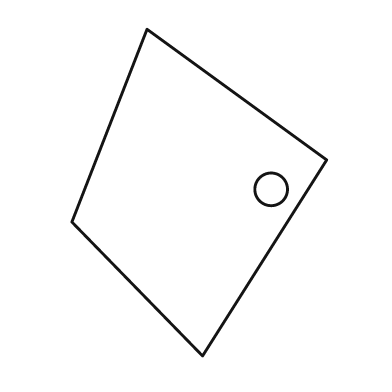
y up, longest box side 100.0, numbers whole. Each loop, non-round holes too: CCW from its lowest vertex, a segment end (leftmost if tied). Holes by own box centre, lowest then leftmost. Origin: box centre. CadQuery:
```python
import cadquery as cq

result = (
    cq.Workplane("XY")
    .moveTo(1.0, -50.0)
    .lineTo(39.0, 10.0)
    .lineTo(-16.0, 50.0)
    .lineTo(-39.0, -9.0)
    .close()
    .moveTo(22.0, 1.0)
    .circle(5.0)
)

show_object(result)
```